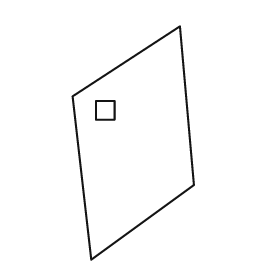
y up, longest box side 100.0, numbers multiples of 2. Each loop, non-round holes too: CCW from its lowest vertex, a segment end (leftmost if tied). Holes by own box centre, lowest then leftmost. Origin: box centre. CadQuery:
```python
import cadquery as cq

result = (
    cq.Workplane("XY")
    .moveTo(-18.0, -50.0)
    .lineTo(26.0, -18.0)
    .lineTo(20.0, 50.0)
    .lineTo(-26.0, 20.0)
    .close()
    .moveTo(-16.0, 10.0)
    .lineTo(-8.0, 10.0)
    .lineTo(-8.0, 18.0)
    .lineTo(-16.0, 18.0)
    .close()
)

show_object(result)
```